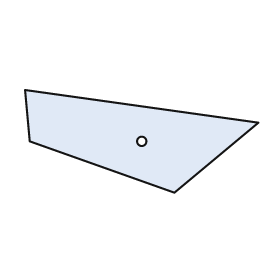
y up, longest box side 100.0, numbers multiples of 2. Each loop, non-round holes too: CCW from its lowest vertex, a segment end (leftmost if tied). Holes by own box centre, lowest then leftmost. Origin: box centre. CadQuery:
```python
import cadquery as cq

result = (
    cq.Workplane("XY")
    .moveTo(14.0, -22.0)
    .lineTo(50.0, 8.0)
    .lineTo(-50.0, 22.0)
    .lineTo(-48.0, 0.0)
    .close()
    .moveTo(0.0, 0.0)
    .circle(2.0)
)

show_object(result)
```